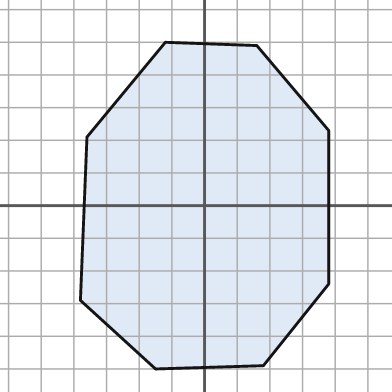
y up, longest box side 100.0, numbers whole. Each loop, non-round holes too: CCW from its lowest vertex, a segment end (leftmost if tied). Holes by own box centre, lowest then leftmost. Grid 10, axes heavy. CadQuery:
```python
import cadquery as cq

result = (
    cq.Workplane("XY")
    .moveTo(-15.0, -50.0)
    .lineTo(18.0, -49.0)
    .lineTo(38.0, -24.0)
    .lineTo(38.0, 23.0)
    .lineTo(16.0, 49.0)
    .lineTo(-12.0, 50.0)
    .lineTo(-36.0, 21.0)
    .lineTo(-38.0, -29.0)
    .close()
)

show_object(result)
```